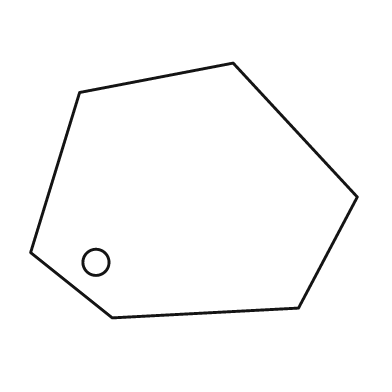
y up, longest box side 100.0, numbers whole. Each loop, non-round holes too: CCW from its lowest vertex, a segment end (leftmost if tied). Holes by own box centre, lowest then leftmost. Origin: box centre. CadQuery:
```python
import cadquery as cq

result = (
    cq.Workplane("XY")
    .moveTo(-25.0, -39.0)
    .lineTo(32.0, -36.0)
    .lineTo(50.0, -2.0)
    .lineTo(12.0, 39.0)
    .lineTo(-35.0, 30.0)
    .lineTo(-50.0, -19.0)
    .close()
    .moveTo(-30.0, -22.0)
    .circle(4.0)
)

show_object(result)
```